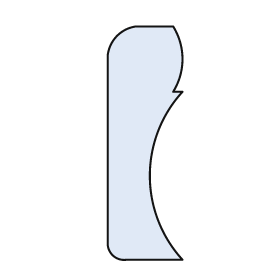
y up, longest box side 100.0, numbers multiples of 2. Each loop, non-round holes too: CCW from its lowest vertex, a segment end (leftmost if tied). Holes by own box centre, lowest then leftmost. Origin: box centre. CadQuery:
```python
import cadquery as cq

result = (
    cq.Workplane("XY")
    .moveTo(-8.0, -50.0)
    .lineTo(16.0, -50.0)
    .threePointArc((2.0, -14.0), (16.0, 22.0))
    .lineTo(12.0, 22.0)
    .threePointArc((16.0, 36.0), (12.0, 50.0))
    .lineTo(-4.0, 50.0)
    .threePointArc((-12.0, 46.0), (-16.0, 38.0))
    .lineTo(-16.0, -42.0)
    .threePointArc((-14.0, -48.0), (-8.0, -50.0))
    .close()
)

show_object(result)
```